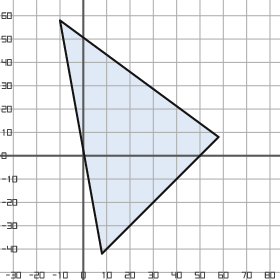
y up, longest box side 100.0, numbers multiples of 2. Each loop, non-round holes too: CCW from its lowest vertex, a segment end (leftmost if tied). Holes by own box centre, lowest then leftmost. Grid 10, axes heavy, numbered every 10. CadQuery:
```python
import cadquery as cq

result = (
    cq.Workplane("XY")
    .moveTo(8.0, -42.0)
    .lineTo(58.0, 8.0)
    .lineTo(-10.0, 58.0)
    .close()
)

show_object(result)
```